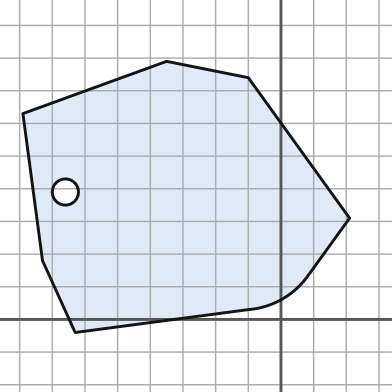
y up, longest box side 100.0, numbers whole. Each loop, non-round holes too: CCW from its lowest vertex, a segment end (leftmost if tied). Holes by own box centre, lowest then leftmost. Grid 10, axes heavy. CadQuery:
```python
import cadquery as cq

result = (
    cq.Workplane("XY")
    .moveTo(-63.0, -4.0)
    .lineTo(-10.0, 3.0)
    .threePointArc((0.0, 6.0), (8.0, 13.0))
    .lineTo(21.0, 31.0)
    .lineTo(-10.0, 74.0)
    .lineTo(-35.0, 79.0)
    .lineTo(-79.0, 63.0)
    .lineTo(-73.0, 18.0)
    .close()
    .moveTo(-66.0, 39.0)
    .circle(4.0)
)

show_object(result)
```